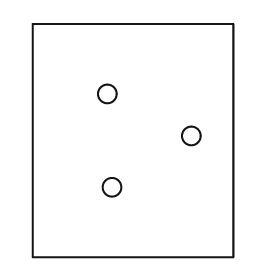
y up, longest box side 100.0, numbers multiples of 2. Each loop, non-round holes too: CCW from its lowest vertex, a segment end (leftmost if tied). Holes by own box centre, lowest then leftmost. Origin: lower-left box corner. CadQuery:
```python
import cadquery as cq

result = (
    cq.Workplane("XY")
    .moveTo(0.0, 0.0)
    .lineTo(86.0, 0.0)
    .lineTo(86.0, 100.0)
    .lineTo(0.0, 100.0)
    .close()
    .moveTo(34.0, 30.0)
    .circle(4.0)
    .moveTo(68.0, 52.0)
    .circle(4.0)
    .moveTo(32.0, 70.0)
    .circle(4.0)
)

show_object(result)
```